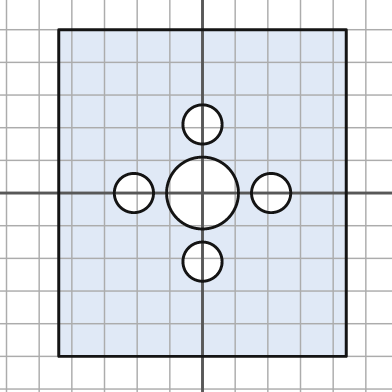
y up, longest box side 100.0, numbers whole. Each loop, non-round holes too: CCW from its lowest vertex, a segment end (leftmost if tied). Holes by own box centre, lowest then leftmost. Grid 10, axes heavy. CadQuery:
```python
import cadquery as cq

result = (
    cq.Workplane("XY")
    .moveTo(-44.0, -50.0)
    .lineTo(44.0, -50.0)
    .lineTo(44.0, 50.0)
    .lineTo(-44.0, 50.0)
    .close()
    .moveTo(0.0, -21.0)
    .circle(6.0)
    .moveTo(-21.0, 0.0)
    .circle(6.0)
    .moveTo(0.0, 0.0)
    .circle(11.0)
    .moveTo(21.0, 0.0)
    .circle(6.0)
    .moveTo(0.0, 21.0)
    .circle(6.0)
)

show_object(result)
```